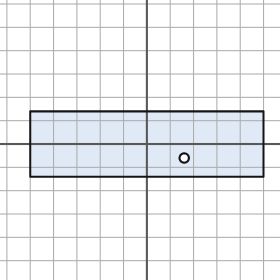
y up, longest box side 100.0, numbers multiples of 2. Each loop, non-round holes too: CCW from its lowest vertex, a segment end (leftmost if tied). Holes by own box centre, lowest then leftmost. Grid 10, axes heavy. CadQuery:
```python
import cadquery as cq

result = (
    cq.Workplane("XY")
    .moveTo(-50.0, -14.0)
    .lineTo(50.0, -14.0)
    .lineTo(50.0, 14.0)
    .lineTo(-50.0, 14.0)
    .close()
    .moveTo(16.0, -6.0)
    .circle(2.0)
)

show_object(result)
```